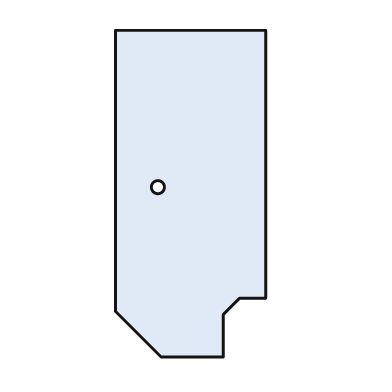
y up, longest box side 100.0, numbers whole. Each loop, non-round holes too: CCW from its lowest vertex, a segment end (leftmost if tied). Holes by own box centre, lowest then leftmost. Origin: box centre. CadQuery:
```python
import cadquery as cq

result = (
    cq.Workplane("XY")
    .moveTo(-9.0, -50.0)
    .lineTo(10.0, -50.0)
    .lineTo(10.0, -37.0)
    .lineTo(15.0, -32.0)
    .lineTo(23.0, -32.0)
    .lineTo(23.0, 50.0)
    .lineTo(-23.0, 50.0)
    .lineTo(-23.0, -36.0)
    .close()
    .moveTo(-10.0, 2.0)
    .circle(2.0)
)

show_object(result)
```